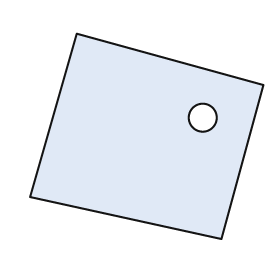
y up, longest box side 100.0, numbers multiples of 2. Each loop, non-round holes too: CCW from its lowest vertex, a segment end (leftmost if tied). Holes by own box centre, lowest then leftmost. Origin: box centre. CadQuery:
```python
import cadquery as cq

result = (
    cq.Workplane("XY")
    .moveTo(32.0, -44.0)
    .lineTo(50.0, 22.0)
    .lineTo(-30.0, 44.0)
    .lineTo(-50.0, -26.0)
    .close()
    .moveTo(24.0, 8.0)
    .circle(6.0)
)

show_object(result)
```